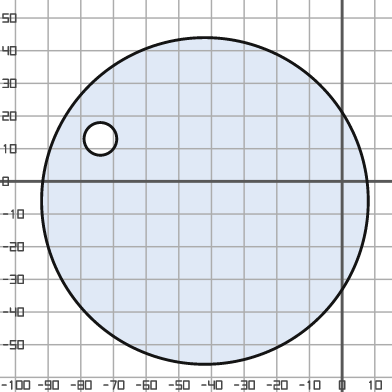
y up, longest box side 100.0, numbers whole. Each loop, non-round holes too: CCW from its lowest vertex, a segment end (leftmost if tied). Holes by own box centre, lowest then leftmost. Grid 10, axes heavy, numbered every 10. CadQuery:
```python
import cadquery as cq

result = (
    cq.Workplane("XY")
    .moveTo(-42.0, -6.0)
    .circle(50.0)
    .moveTo(-74.0, 13.0)
    .circle(5.0)
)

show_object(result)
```